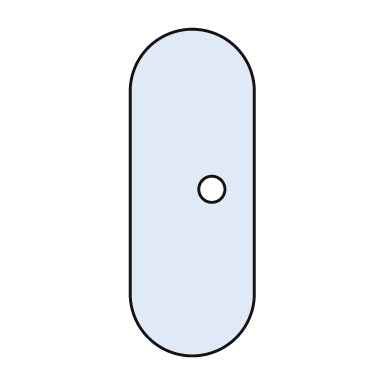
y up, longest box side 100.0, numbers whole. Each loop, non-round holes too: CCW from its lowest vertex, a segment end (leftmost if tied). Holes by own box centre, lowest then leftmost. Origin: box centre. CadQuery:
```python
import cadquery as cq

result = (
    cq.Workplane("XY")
    .moveTo(-19.0, -31.0)
    .threePointArc((0.0, -50.0), (19.0, -31.0))
    .lineTo(19.0, 31.0)
    .threePointArc((0.0, 50.0), (-19.0, 31.0))
    .close()
    .moveTo(6.0, 1.0)
    .circle(4.0)
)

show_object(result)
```